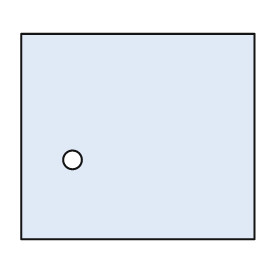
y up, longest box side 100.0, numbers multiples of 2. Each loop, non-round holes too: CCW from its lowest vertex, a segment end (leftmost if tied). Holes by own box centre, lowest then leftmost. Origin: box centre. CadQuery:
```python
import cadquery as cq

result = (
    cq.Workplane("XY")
    .moveTo(-50.0, -44.0)
    .lineTo(50.0, -44.0)
    .lineTo(50.0, 44.0)
    .lineTo(-50.0, 44.0)
    .close()
    .moveTo(-28.0, -10.0)
    .circle(4.0)
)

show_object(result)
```